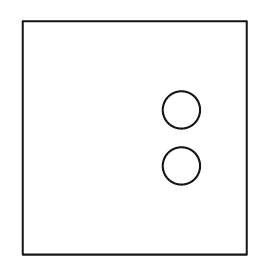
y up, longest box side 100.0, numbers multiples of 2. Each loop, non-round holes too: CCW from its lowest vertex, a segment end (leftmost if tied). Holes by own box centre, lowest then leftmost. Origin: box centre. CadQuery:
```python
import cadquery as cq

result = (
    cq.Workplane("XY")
    .moveTo(-48.0, -50.0)
    .lineTo(48.0, -50.0)
    .lineTo(48.0, 50.0)
    .lineTo(-48.0, 50.0)
    .close()
    .moveTo(20.0, -12.0)
    .circle(8.0)
    .moveTo(20.0, 12.0)
    .circle(8.0)
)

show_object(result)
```